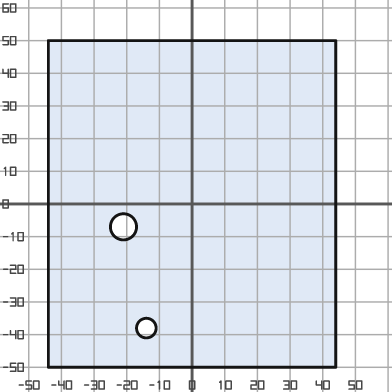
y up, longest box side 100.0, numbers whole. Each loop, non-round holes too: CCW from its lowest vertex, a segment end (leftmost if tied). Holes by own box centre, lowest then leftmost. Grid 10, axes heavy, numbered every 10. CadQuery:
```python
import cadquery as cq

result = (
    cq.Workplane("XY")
    .moveTo(-44.0, -50.0)
    .lineTo(44.0, -50.0)
    .lineTo(44.0, 50.0)
    .lineTo(-44.0, 50.0)
    .close()
    .moveTo(-14.0, -38.0)
    .circle(3.0)
    .moveTo(-21.0, -7.0)
    .circle(4.0)
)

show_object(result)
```